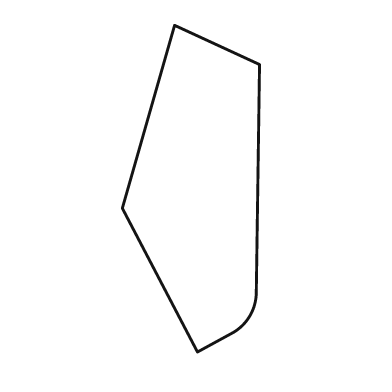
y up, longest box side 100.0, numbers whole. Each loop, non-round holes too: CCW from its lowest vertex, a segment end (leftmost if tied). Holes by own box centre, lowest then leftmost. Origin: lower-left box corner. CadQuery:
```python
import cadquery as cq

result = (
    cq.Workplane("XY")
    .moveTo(23.0, 0.0)
    .lineTo(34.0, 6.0)
    .threePointArc((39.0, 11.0), (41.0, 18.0))
    .lineTo(42.0, 88.0)
    .lineTo(16.0, 100.0)
    .lineTo(0.0, 44.0)
    .close()
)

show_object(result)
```